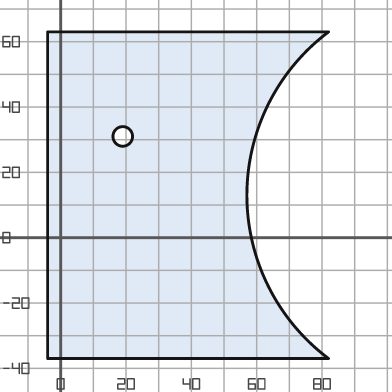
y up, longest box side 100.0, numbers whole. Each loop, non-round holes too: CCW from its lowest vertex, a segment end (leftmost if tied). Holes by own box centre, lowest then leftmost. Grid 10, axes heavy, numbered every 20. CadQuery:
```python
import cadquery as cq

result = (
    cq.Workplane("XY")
    .moveTo(-4.0, -37.0)
    .lineTo(82.0, -37.0)
    .threePointArc((57.0, 13.0), (82.0, 63.0))
    .lineTo(-4.0, 63.0)
    .close()
    .moveTo(19.0, 31.0)
    .circle(3.0)
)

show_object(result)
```